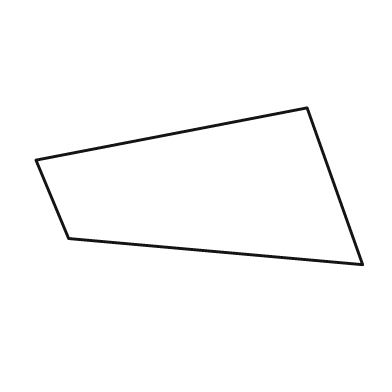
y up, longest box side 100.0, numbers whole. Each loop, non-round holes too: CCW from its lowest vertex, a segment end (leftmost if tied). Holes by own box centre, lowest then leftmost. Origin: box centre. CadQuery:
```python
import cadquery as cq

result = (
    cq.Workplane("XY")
    .moveTo(50.0, -24.0)
    .lineTo(33.0, 24.0)
    .lineTo(-50.0, 8.0)
    .lineTo(-40.0, -16.0)
    .close()
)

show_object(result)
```